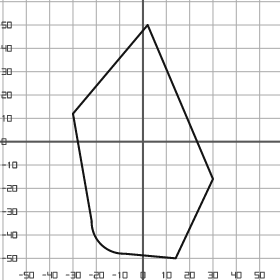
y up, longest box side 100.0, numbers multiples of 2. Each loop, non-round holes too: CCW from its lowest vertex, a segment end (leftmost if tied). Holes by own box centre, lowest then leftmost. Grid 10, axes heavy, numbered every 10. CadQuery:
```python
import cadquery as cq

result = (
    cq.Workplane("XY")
    .moveTo(14.0, -50.0)
    .lineTo(30.0, -16.0)
    .lineTo(2.0, 50.0)
    .lineTo(-30.0, 12.0)
    .lineTo(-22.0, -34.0)
    .threePointArc((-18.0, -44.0), (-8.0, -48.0))
    .close()
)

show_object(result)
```